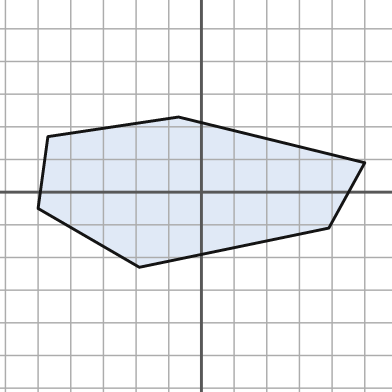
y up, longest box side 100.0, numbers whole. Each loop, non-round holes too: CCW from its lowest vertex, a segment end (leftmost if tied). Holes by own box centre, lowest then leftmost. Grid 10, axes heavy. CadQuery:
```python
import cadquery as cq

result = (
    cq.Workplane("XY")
    .moveTo(-19.0, -23.0)
    .lineTo(39.0, -11.0)
    .lineTo(50.0, 9.0)
    .lineTo(-7.0, 23.0)
    .lineTo(-47.0, 17.0)
    .lineTo(-50.0, -5.0)
    .close()
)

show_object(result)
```